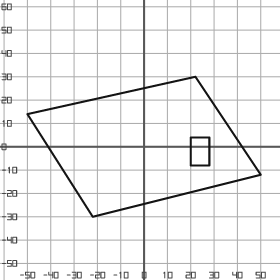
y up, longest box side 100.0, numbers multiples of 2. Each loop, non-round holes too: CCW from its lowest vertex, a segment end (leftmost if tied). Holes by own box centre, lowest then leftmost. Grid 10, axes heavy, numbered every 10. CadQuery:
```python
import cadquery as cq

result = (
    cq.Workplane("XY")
    .moveTo(-22.0, -30.0)
    .lineTo(50.0, -12.0)
    .lineTo(22.0, 30.0)
    .lineTo(-50.0, 14.0)
    .close()
    .moveTo(20.0, -8.0)
    .lineTo(28.0, -8.0)
    .lineTo(28.0, 4.0)
    .lineTo(20.0, 4.0)
    .close()
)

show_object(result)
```